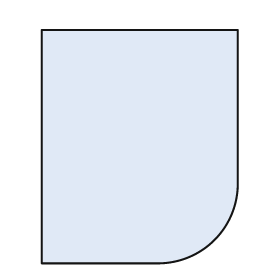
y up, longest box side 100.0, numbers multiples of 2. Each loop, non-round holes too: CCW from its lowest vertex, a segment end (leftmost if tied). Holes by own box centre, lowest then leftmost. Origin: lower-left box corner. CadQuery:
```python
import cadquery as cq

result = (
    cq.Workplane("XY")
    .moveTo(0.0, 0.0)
    .lineTo(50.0, 0.0)
    .threePointArc((74.0, 10.0), (84.0, 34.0))
    .lineTo(84.0, 100.0)
    .lineTo(0.0, 100.0)
    .close()
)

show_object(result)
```